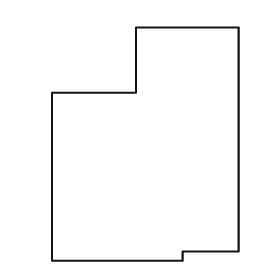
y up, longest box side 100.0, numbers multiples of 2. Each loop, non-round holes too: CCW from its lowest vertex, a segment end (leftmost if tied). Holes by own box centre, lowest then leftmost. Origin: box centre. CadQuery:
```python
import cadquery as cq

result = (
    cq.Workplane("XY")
    .moveTo(-40.0, -50.0)
    .lineTo(16.0, -50.0)
    .lineTo(16.0, -46.0)
    .lineTo(40.0, -46.0)
    .lineTo(40.0, 50.0)
    .lineTo(-4.0, 50.0)
    .lineTo(-4.0, 22.0)
    .lineTo(-40.0, 22.0)
    .close()
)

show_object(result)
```